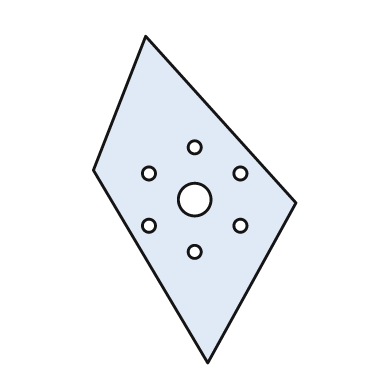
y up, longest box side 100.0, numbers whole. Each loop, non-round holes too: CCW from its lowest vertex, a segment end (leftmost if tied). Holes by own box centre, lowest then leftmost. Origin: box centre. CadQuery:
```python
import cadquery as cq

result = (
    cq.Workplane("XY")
    .moveTo(4.0, -50.0)
    .lineTo(31.0, -1.0)
    .lineTo(-15.0, 50.0)
    .lineTo(-31.0, 9.0)
    .close()
    .moveTo(0.0, -16.0)
    .circle(2.0)
    .moveTo(-14.0, -8.0)
    .circle(2.0)
    .moveTo(14.0, -8.0)
    .circle(2.0)
    .moveTo(0.0, 0.0)
    .circle(5.0)
    .moveTo(-14.0, 8.0)
    .circle(2.0)
    .moveTo(14.0, 8.0)
    .circle(2.0)
    .moveTo(0.0, 16.0)
    .circle(2.0)
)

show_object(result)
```